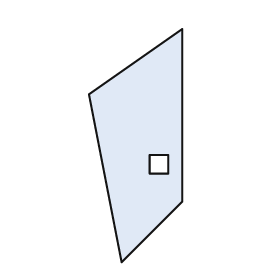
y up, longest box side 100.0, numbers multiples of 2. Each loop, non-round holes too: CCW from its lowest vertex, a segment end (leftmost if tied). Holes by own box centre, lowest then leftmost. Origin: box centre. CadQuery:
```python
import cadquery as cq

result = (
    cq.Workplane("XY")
    .moveTo(-6.0, -50.0)
    .lineTo(20.0, -24.0)
    .lineTo(20.0, 50.0)
    .lineTo(-20.0, 22.0)
    .close()
    .moveTo(6.0, -12.0)
    .lineTo(14.0, -12.0)
    .lineTo(14.0, -4.0)
    .lineTo(6.0, -4.0)
    .close()
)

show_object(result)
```